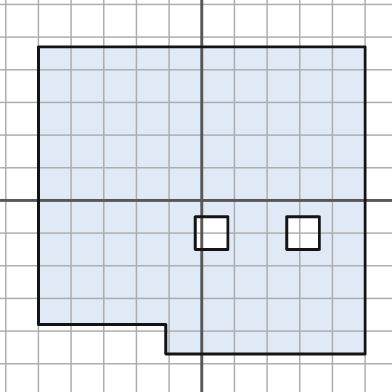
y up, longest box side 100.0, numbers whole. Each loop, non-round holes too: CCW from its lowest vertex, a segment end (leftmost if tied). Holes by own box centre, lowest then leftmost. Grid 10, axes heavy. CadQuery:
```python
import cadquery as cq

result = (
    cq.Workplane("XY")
    .moveTo(-11.0, -47.0)
    .lineTo(50.0, -47.0)
    .lineTo(50.0, 47.0)
    .lineTo(-50.0, 47.0)
    .lineTo(-50.0, -38.0)
    .lineTo(-11.0, -38.0)
    .close()
    .moveTo(-2.0, -15.0)
    .lineTo(8.0, -15.0)
    .lineTo(8.0, -5.0)
    .lineTo(-2.0, -5.0)
    .close()
    .moveTo(26.0, -15.0)
    .lineTo(36.0, -15.0)
    .lineTo(36.0, -5.0)
    .lineTo(26.0, -5.0)
    .close()
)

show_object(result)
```